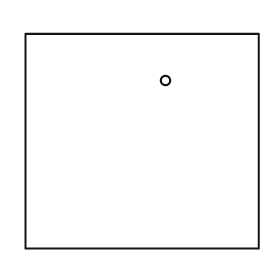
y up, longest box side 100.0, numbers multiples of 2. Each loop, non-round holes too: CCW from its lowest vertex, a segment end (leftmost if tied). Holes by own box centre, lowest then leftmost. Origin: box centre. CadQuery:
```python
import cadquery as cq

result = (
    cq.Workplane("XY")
    .moveTo(-50.0, -46.0)
    .lineTo(50.0, -46.0)
    .lineTo(50.0, 46.0)
    .lineTo(-50.0, 46.0)
    .close()
    .moveTo(10.0, 26.0)
    .circle(2.0)
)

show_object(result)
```